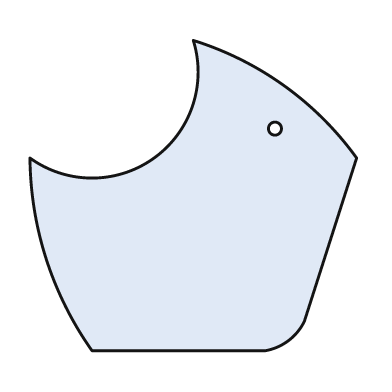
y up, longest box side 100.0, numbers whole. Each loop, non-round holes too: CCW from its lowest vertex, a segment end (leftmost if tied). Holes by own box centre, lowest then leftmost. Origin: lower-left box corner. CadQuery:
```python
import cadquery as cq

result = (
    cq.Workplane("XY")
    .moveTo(19.0, 0.0)
    .lineTo(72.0, 0.0)
    .threePointArc((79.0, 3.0), (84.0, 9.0))
    .lineTo(100.0, 59.0)
    .threePointArc((78.0, 81.0), (50.0, 95.0))
    .threePointArc((38.0, 59.0), (0.0, 59.0))
    .threePointArc((5.0, 28.0), (19.0, 0.0))
    .close()
    .moveTo(75.0, 68.0)
    .circle(2.0)
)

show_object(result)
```